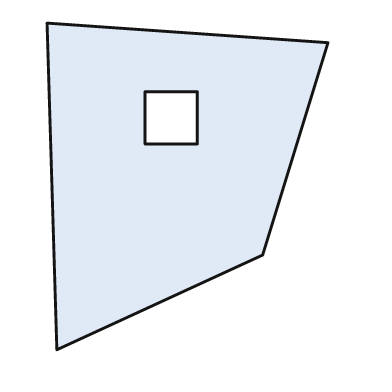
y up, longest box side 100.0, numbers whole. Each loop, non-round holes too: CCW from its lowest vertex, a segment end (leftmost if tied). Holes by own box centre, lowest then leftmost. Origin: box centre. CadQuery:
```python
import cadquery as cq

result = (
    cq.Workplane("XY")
    .moveTo(-40.0, -50.0)
    .lineTo(23.0, -21.0)
    .lineTo(43.0, 44.0)
    .lineTo(-43.0, 50.0)
    .close()
    .moveTo(-13.0, 13.0)
    .lineTo(3.0, 13.0)
    .lineTo(3.0, 29.0)
    .lineTo(-13.0, 29.0)
    .close()
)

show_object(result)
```